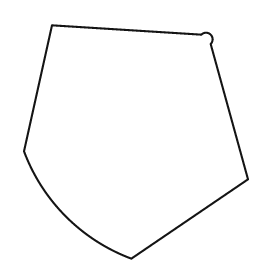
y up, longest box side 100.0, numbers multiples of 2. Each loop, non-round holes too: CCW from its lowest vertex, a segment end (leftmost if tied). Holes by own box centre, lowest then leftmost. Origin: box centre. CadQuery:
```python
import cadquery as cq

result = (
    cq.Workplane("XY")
    .moveTo(-2.0, -50.0)
    .lineTo(48.0, -16.0)
    .lineTo(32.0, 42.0)
    .threePointArc((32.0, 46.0), (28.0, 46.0))
    .lineTo(-36.0, 50.0)
    .lineTo(-48.0, -4.0)
    .threePointArc((-30.0, -32.0), (-2.0, -50.0))
    .close()
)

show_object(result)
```